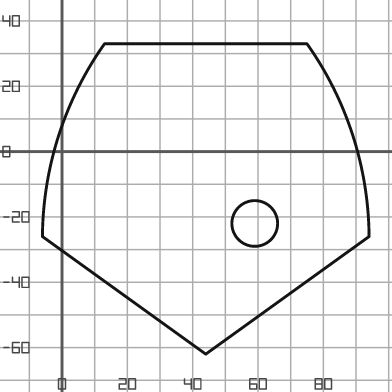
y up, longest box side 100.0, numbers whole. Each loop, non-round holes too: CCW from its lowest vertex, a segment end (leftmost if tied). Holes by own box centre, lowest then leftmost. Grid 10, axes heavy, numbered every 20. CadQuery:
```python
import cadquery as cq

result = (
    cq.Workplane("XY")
    .moveTo(44.0, -62.0)
    .lineTo(94.0, -26.0)
    .threePointArc((89.0, 5.0), (75.0, 33.0))
    .lineTo(13.0, 33.0)
    .threePointArc((-1.0, 5.0), (-6.0, -26.0))
    .close()
    .moveTo(59.0, -22.0)
    .circle(7.0)
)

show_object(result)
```